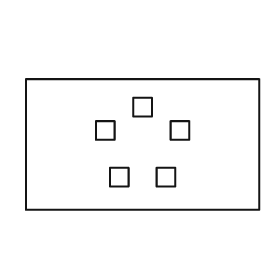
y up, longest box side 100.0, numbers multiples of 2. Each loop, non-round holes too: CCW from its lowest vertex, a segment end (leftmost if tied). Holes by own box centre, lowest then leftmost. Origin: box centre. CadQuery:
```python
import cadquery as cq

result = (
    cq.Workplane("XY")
    .moveTo(-50.0, -28.0)
    .lineTo(50.0, -28.0)
    .lineTo(50.0, 28.0)
    .lineTo(-50.0, 28.0)
    .close()
    .moveTo(-14.0, -18.0)
    .lineTo(-6.0, -18.0)
    .lineTo(-6.0, -10.0)
    .lineTo(-14.0, -10.0)
    .close()
    .moveTo(6.0, -18.0)
    .lineTo(14.0, -18.0)
    .lineTo(14.0, -10.0)
    .lineTo(6.0, -10.0)
    .close()
    .moveTo(-20.0, 2.0)
    .lineTo(-12.0, 2.0)
    .lineTo(-12.0, 10.0)
    .lineTo(-20.0, 10.0)
    .close()
    .moveTo(12.0, 2.0)
    .lineTo(20.0, 2.0)
    .lineTo(20.0, 10.0)
    .lineTo(12.0, 10.0)
    .close()
    .moveTo(-4.0, 12.0)
    .lineTo(4.0, 12.0)
    .lineTo(4.0, 20.0)
    .lineTo(-4.0, 20.0)
    .close()
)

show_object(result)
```